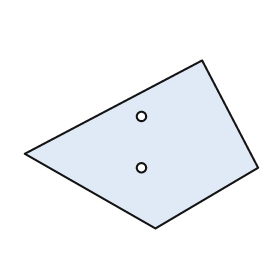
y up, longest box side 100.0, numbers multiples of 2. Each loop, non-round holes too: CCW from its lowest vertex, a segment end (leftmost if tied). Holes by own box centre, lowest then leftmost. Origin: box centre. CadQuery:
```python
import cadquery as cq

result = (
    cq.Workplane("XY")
    .moveTo(6.0, -36.0)
    .lineTo(50.0, -10.0)
    .lineTo(26.0, 36.0)
    .lineTo(-50.0, -4.0)
    .close()
    .moveTo(0.0, -10.0)
    .circle(2.0)
    .moveTo(0.0, 12.0)
    .circle(2.0)
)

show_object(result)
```